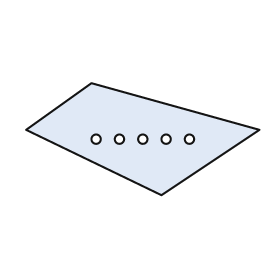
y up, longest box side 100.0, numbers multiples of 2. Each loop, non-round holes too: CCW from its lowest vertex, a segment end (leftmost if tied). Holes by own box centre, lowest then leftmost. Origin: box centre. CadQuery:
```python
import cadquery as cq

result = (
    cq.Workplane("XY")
    .moveTo(8.0, -24.0)
    .lineTo(50.0, 4.0)
    .lineTo(-22.0, 24.0)
    .lineTo(-50.0, 4.0)
    .close()
    .moveTo(-20.0, 0.0)
    .circle(2.0)
    .moveTo(-10.0, 0.0)
    .circle(2.0)
    .moveTo(0.0, 0.0)
    .circle(2.0)
    .moveTo(10.0, 0.0)
    .circle(2.0)
    .moveTo(20.0, 0.0)
    .circle(2.0)
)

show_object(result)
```